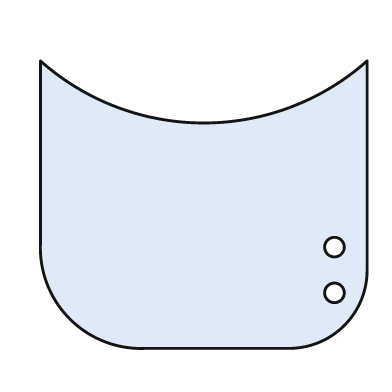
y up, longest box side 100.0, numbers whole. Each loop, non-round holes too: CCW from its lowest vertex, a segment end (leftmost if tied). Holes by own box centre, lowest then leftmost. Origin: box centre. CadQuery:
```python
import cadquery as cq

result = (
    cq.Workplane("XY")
    .moveTo(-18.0, -44.0)
    .lineTo(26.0, -44.0)
    .threePointArc((43.0, -37.0), (50.0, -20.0))
    .lineTo(50.0, 44.0)
    .threePointArc((0.0, 25.0), (-50.0, 44.0))
    .lineTo(-50.0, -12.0)
    .threePointArc((-41.0, -35.0), (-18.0, -44.0))
    .close()
    .moveTo(40.0, -27.0)
    .circle(3.0)
    .moveTo(40.0, -13.0)
    .circle(3.0)
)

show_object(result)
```